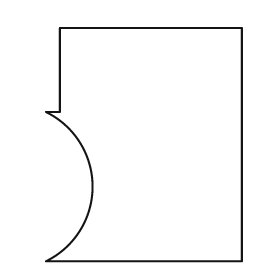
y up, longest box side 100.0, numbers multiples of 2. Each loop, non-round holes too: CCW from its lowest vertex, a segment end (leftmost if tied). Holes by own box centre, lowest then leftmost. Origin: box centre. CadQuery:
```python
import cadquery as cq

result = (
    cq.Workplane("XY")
    .moveTo(-42.0, -50.0)
    .lineTo(42.0, -50.0)
    .lineTo(42.0, 50.0)
    .lineTo(-36.0, 50.0)
    .lineTo(-36.0, 14.0)
    .lineTo(-42.0, 14.0)
    .threePointArc((-22.0, -18.0), (-42.0, -50.0))
    .close()
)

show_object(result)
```